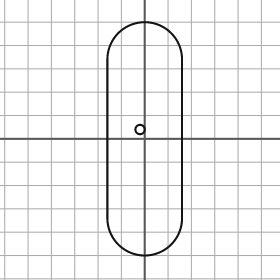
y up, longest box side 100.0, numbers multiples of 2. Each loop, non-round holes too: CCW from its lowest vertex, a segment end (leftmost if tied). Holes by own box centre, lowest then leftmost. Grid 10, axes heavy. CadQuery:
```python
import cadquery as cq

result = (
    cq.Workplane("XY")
    .moveTo(-16.0, -34.0)
    .threePointArc((0.0, -50.0), (16.0, -34.0))
    .lineTo(16.0, 34.0)
    .threePointArc((0.0, 50.0), (-16.0, 34.0))
    .close()
    .moveTo(-2.0, 4.0)
    .circle(2.0)
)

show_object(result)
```